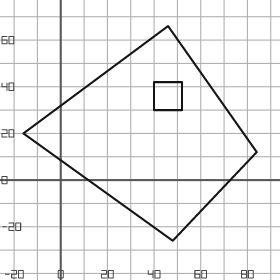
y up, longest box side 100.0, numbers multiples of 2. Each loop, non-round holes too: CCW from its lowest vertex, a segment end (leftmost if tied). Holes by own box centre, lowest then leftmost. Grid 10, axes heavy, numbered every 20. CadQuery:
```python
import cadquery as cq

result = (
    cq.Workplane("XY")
    .moveTo(48.0, -26.0)
    .lineTo(84.0, 12.0)
    .lineTo(46.0, 66.0)
    .lineTo(-16.0, 20.0)
    .close()
    .moveTo(40.0, 30.0)
    .lineTo(52.0, 30.0)
    .lineTo(52.0, 42.0)
    .lineTo(40.0, 42.0)
    .close()
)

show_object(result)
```